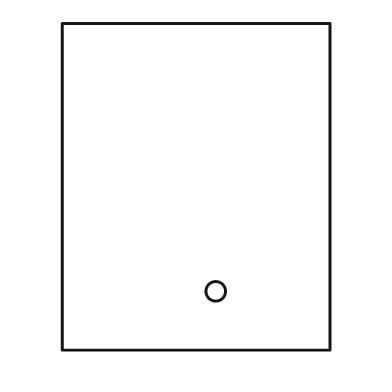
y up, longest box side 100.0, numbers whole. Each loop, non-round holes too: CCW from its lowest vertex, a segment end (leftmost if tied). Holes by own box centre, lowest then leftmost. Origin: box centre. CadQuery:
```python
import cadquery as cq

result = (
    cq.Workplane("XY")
    .moveTo(-41.0, -50.0)
    .lineTo(41.0, -50.0)
    .lineTo(41.0, 50.0)
    .lineTo(-41.0, 50.0)
    .close()
    .moveTo(6.0, -32.0)
    .circle(3.0)
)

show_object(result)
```